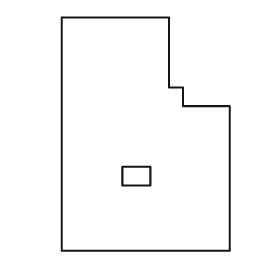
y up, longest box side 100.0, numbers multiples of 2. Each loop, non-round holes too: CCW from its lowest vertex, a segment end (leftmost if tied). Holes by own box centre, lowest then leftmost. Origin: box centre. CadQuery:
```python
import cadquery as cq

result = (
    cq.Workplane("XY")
    .moveTo(-36.0, -50.0)
    .lineTo(36.0, -50.0)
    .lineTo(36.0, 12.0)
    .lineTo(16.0, 12.0)
    .lineTo(16.0, 20.0)
    .lineTo(10.0, 20.0)
    .lineTo(10.0, 50.0)
    .lineTo(-36.0, 50.0)
    .close()
    .moveTo(-10.0, -22.0)
    .lineTo(2.0, -22.0)
    .lineTo(2.0, -14.0)
    .lineTo(-10.0, -14.0)
    .close()
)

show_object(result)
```